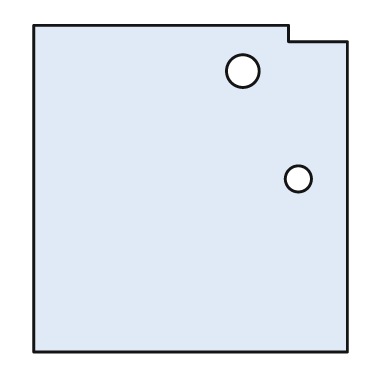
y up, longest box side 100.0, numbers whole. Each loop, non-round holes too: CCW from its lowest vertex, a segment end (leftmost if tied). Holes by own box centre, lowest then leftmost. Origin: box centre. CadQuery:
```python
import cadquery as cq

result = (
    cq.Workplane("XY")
    .moveTo(-48.0, -50.0)
    .lineTo(48.0, -50.0)
    .lineTo(48.0, 45.0)
    .lineTo(30.0, 45.0)
    .lineTo(30.0, 50.0)
    .lineTo(-48.0, 50.0)
    .close()
    .moveTo(33.0, 3.0)
    .circle(4.0)
    .moveTo(16.0, 36.0)
    .circle(5.0)
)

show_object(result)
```